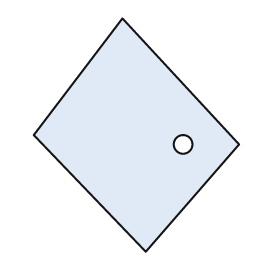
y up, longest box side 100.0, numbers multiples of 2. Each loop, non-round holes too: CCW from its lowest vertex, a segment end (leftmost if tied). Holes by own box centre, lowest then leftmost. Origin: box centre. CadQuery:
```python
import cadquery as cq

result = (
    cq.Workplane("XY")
    .moveTo(4.0, -50.0)
    .lineTo(44.0, -4.0)
    .lineTo(-6.0, 50.0)
    .lineTo(-44.0, 0.0)
    .close()
    .moveTo(20.0, -4.0)
    .circle(4.0)
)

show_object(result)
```